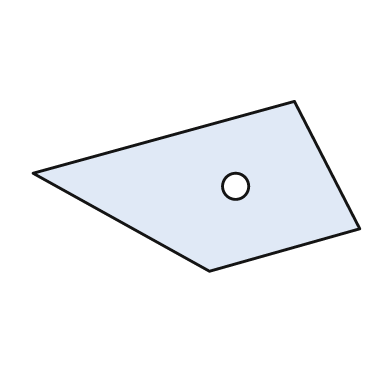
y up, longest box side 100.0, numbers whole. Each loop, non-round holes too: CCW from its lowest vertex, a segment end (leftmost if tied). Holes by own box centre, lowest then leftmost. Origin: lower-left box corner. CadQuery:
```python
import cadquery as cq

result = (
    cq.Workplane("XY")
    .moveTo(54.0, 0.0)
    .lineTo(100.0, 13.0)
    .lineTo(80.0, 52.0)
    .lineTo(0.0, 30.0)
    .close()
    .moveTo(62.0, 26.0)
    .circle(4.0)
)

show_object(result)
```